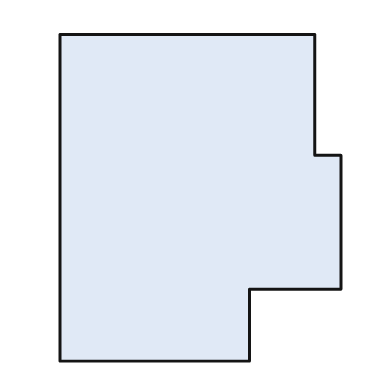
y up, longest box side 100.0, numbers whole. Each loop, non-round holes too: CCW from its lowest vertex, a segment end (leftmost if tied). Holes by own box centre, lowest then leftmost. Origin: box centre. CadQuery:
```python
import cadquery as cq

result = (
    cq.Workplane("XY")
    .moveTo(-43.0, -50.0)
    .lineTo(15.0, -50.0)
    .lineTo(15.0, -28.0)
    .lineTo(43.0, -28.0)
    .lineTo(43.0, 13.0)
    .lineTo(35.0, 13.0)
    .lineTo(35.0, 50.0)
    .lineTo(-43.0, 50.0)
    .close()
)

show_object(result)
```